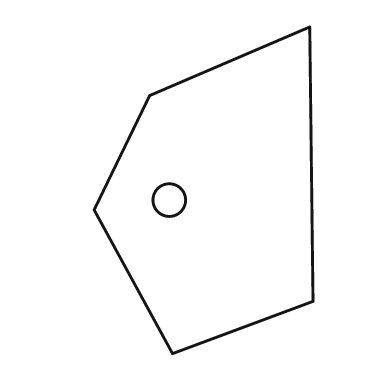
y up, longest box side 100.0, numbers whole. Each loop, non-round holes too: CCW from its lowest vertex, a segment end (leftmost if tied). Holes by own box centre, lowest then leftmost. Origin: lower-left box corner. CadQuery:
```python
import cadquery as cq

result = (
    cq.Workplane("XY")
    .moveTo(24.0, 0.0)
    .lineTo(67.0, 16.0)
    .lineTo(66.0, 100.0)
    .lineTo(17.0, 79.0)
    .lineTo(0.0, 44.0)
    .close()
    .moveTo(23.0, 47.0)
    .circle(5.0)
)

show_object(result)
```